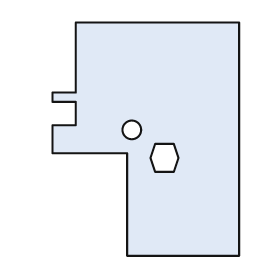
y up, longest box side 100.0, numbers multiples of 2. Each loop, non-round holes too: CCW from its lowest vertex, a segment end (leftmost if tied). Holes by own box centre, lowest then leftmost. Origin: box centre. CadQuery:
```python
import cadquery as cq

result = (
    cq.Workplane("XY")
    .moveTo(-8.0, -50.0)
    .lineTo(40.0, -50.0)
    .lineTo(40.0, 50.0)
    .lineTo(-30.0, 50.0)
    .lineTo(-30.0, 20.0)
    .lineTo(-40.0, 20.0)
    .lineTo(-40.0, 16.0)
    .lineTo(-30.0, 16.0)
    .lineTo(-30.0, 6.0)
    .lineTo(-40.0, 6.0)
    .lineTo(-40.0, -6.0)
    .lineTo(-8.0, -6.0)
    .close()
    .moveTo(4.0, -14.0)
    .lineTo(12.0, -14.0)
    .lineTo(14.0, -8.0)
    .lineTo(12.0, -2.0)
    .lineTo(4.0, -2.0)
    .lineTo(2.0, -8.0)
    .close()
    .moveTo(-6.0, 4.0)
    .circle(4.0)
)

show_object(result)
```